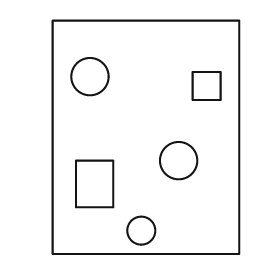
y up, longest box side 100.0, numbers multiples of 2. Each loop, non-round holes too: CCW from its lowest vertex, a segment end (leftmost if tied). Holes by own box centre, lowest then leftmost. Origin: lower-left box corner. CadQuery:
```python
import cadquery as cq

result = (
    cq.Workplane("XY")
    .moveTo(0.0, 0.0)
    .lineTo(80.0, 0.0)
    .lineTo(80.0, 100.0)
    .lineTo(0.0, 100.0)
    .close()
    .moveTo(38.0, 10.0)
    .circle(6.0)
    .moveTo(10.0, 20.0)
    .lineTo(26.0, 20.0)
    .lineTo(26.0, 40.0)
    .lineTo(10.0, 40.0)
    .close()
    .moveTo(54.0, 40.0)
    .circle(8.0)
    .moveTo(60.0, 66.0)
    .lineTo(72.0, 66.0)
    .lineTo(72.0, 78.0)
    .lineTo(60.0, 78.0)
    .close()
    .moveTo(16.0, 76.0)
    .circle(8.0)
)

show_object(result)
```